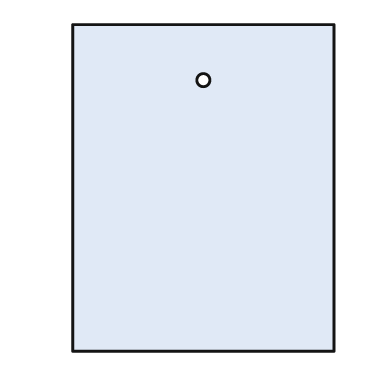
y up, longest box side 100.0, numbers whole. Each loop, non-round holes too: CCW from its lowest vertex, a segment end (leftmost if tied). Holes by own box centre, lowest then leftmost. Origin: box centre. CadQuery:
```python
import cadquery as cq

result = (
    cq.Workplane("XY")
    .moveTo(-40.0, -50.0)
    .lineTo(40.0, -50.0)
    .lineTo(40.0, 50.0)
    .lineTo(-40.0, 50.0)
    .close()
    .moveTo(0.0, 33.0)
    .circle(2.0)
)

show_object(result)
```